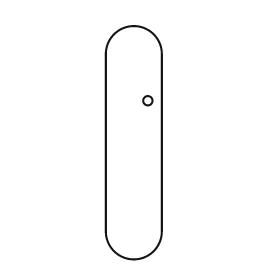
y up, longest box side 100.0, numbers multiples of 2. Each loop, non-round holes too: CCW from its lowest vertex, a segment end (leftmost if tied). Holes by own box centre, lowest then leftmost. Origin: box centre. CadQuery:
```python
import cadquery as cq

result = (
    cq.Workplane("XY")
    .moveTo(-12.0, -38.0)
    .threePointArc((0.0, -50.0), (12.0, -38.0))
    .lineTo(12.0, 38.0)
    .threePointArc((0.0, 50.0), (-12.0, 38.0))
    .close()
    .moveTo(6.0, 18.0)
    .circle(2.0)
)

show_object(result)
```